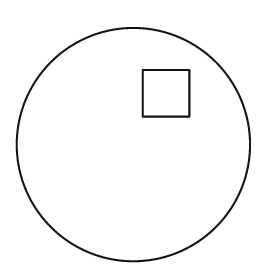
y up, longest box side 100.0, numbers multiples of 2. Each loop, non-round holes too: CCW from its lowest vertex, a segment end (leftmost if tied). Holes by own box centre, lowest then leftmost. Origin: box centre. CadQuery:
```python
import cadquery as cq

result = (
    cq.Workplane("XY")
    .moveTo(0.0, 0.0)
    .circle(50.0)
    .moveTo(4.0, 12.0)
    .lineTo(24.0, 12.0)
    .lineTo(24.0, 32.0)
    .lineTo(4.0, 32.0)
    .close()
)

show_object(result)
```